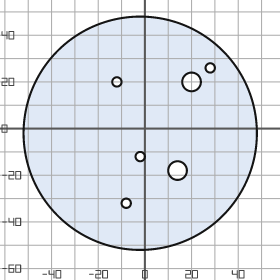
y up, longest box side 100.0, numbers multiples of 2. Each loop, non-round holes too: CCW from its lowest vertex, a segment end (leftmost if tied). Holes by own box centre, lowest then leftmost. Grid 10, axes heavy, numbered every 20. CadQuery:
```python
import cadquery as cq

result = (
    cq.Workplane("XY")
    .moveTo(-2.0, -2.0)
    .circle(50.0)
    .moveTo(-8.0, -32.0)
    .circle(2.0)
    .moveTo(14.0, -18.0)
    .circle(4.0)
    .moveTo(-2.0, -12.0)
    .circle(2.0)
    .moveTo(-12.0, 20.0)
    .circle(2.0)
    .moveTo(20.0, 20.0)
    .circle(4.0)
    .moveTo(28.0, 26.0)
    .circle(2.0)
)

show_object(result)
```